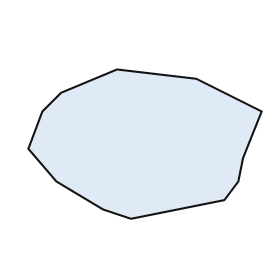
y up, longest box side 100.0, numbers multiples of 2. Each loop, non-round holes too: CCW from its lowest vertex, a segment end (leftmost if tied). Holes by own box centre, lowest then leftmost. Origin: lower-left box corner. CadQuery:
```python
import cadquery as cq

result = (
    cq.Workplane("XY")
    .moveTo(44.0, 0.0)
    .lineTo(84.0, 8.0)
    .lineTo(90.0, 16.0)
    .lineTo(92.0, 26.0)
    .lineTo(100.0, 46.0)
    .lineTo(72.0, 60.0)
    .lineTo(38.0, 64.0)
    .lineTo(14.0, 54.0)
    .lineTo(6.0, 46.0)
    .lineTo(0.0, 30.0)
    .lineTo(12.0, 16.0)
    .lineTo(32.0, 4.0)
    .close()
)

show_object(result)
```